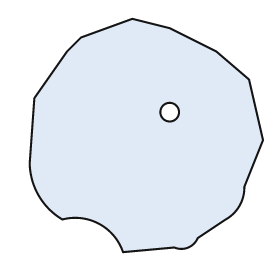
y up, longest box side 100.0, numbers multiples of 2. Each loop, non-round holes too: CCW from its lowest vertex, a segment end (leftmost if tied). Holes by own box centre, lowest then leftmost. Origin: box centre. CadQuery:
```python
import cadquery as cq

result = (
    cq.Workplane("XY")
    .moveTo(-10.0, -50.0)
    .lineTo(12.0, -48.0)
    .threePointArc((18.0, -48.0), (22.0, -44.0))
    .lineTo(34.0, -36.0)
    .threePointArc((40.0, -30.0), (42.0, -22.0))
    .lineTo(50.0, -2.0)
    .lineTo(44.0, 24.0)
    .lineTo(30.0, 36.0)
    .lineTo(10.0, 46.0)
    .lineTo(-6.0, 50.0)
    .lineTo(-28.0, 42.0)
    .lineTo(-34.0, 36.0)
    .lineTo(-48.0, 16.0)
    .lineTo(-50.0, -12.0)
    .threePointArc((-46.0, -26.0), (-36.0, -36.0))
    .threePointArc((-20.0, -38.0), (-10.0, -50.0))
    .close()
    .moveTo(10.0, 10.0)
    .circle(4.0)
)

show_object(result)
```